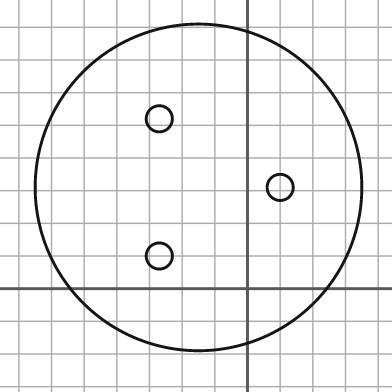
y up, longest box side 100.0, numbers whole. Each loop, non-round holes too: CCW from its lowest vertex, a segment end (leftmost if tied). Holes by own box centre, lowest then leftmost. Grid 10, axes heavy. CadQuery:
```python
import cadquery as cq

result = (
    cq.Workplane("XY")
    .moveTo(-15.0, 31.0)
    .circle(50.0)
    .moveTo(-27.0, 10.0)
    .circle(4.0)
    .moveTo(10.0, 31.0)
    .circle(4.0)
    .moveTo(-27.0, 52.0)
    .circle(4.0)
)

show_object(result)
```